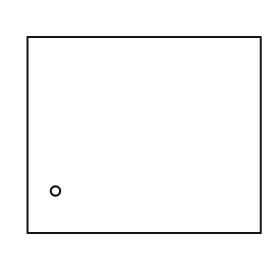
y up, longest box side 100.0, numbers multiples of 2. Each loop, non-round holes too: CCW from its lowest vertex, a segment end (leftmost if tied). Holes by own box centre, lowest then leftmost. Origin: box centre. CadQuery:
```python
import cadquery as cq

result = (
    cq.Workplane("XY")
    .moveTo(-50.0, -42.0)
    .lineTo(50.0, -42.0)
    .lineTo(50.0, 42.0)
    .lineTo(-50.0, 42.0)
    .close()
    .moveTo(-38.0, -24.0)
    .circle(2.0)
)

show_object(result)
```